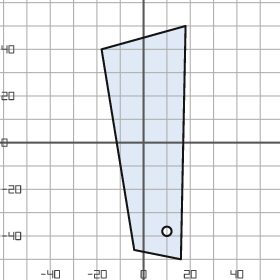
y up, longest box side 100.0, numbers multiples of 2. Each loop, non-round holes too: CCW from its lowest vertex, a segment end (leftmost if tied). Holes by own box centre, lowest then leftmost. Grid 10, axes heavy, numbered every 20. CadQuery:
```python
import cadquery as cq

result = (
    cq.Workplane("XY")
    .moveTo(16.0, -50.0)
    .lineTo(18.0, 50.0)
    .lineTo(-18.0, 40.0)
    .lineTo(-4.0, -46.0)
    .close()
    .moveTo(10.0, -38.0)
    .circle(2.0)
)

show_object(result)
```